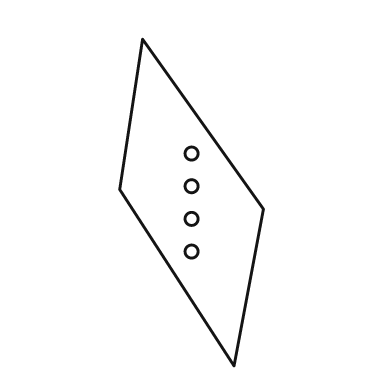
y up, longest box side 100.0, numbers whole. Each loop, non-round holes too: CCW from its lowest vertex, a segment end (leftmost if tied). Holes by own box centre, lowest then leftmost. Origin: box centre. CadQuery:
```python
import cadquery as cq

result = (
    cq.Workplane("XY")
    .moveTo(13.0, -50.0)
    .lineTo(22.0, -2.0)
    .lineTo(-15.0, 50.0)
    .lineTo(-22.0, 4.0)
    .close()
    .moveTo(0.0, -15.0)
    .circle(2.0)
    .moveTo(0.0, -5.0)
    .circle(2.0)
    .moveTo(0.0, 5.0)
    .circle(2.0)
    .moveTo(0.0, 15.0)
    .circle(2.0)
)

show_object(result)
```